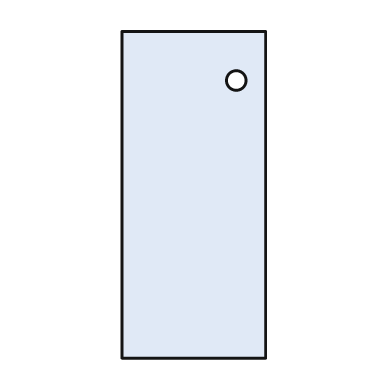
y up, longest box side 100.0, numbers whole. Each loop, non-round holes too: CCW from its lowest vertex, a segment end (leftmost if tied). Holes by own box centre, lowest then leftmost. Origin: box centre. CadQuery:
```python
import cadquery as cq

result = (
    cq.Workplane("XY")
    .moveTo(-22.0, -50.0)
    .lineTo(22.0, -50.0)
    .lineTo(22.0, 50.0)
    .lineTo(-22.0, 50.0)
    .close()
    .moveTo(13.0, 35.0)
    .circle(3.0)
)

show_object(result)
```